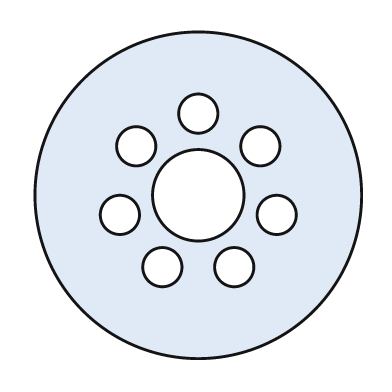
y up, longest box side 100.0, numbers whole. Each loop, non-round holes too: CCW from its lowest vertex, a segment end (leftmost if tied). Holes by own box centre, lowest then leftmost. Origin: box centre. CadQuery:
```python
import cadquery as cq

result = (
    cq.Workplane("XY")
    .moveTo(0.0, 0.0)
    .circle(50.0)
    .moveTo(-11.0, -22.0)
    .circle(6.0)
    .moveTo(11.0, -22.0)
    .circle(6.0)
    .moveTo(-24.0, -6.0)
    .circle(6.0)
    .moveTo(24.0, -6.0)
    .circle(6.0)
    .moveTo(0.0, 0.0)
    .circle(14.0)
    .moveTo(-19.0, 15.0)
    .circle(6.0)
    .moveTo(19.0, 15.0)
    .circle(6.0)
    .moveTo(0.0, 25.0)
    .circle(6.0)
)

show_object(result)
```